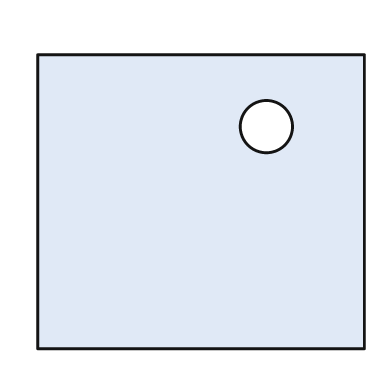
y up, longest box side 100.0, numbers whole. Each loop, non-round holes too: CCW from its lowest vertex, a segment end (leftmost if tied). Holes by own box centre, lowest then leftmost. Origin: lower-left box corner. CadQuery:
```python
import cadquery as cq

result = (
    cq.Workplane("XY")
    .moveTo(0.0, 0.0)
    .lineTo(100.0, 0.0)
    .lineTo(100.0, 90.0)
    .lineTo(0.0, 90.0)
    .close()
    .moveTo(70.0, 68.0)
    .circle(8.0)
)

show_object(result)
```